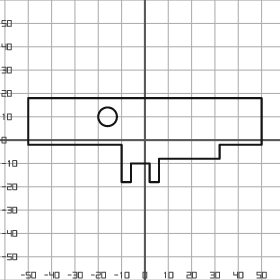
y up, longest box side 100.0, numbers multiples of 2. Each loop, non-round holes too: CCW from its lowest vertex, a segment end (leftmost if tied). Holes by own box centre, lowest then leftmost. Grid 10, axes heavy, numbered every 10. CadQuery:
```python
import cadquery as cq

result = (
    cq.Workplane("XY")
    .moveTo(-10.0, -18.0)
    .lineTo(-6.0, -18.0)
    .lineTo(-6.0, -10.0)
    .lineTo(2.0, -10.0)
    .lineTo(2.0, -18.0)
    .lineTo(6.0, -18.0)
    .lineTo(6.0, -8.0)
    .lineTo(32.0, -8.0)
    .lineTo(32.0, -2.0)
    .lineTo(50.0, -2.0)
    .lineTo(50.0, 18.0)
    .lineTo(-50.0, 18.0)
    .lineTo(-50.0, -2.0)
    .lineTo(-10.0, -2.0)
    .close()
    .moveTo(-16.0, 10.0)
    .circle(4.0)
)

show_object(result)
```